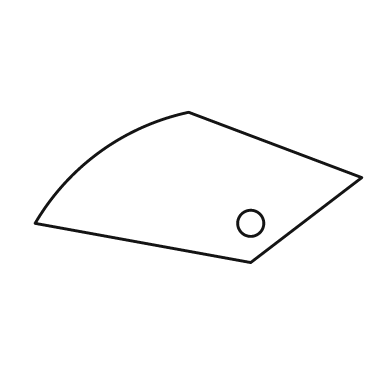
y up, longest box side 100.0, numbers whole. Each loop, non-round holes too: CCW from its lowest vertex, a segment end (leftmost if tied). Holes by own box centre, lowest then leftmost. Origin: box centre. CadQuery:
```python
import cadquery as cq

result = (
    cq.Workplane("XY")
    .moveTo(16.0, -23.0)
    .lineTo(50.0, 3.0)
    .lineTo(-3.0, 23.0)
    .threePointArc((-30.0, 11.0), (-50.0, -11.0))
    .close()
    .moveTo(16.0, -11.0)
    .circle(4.0)
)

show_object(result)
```